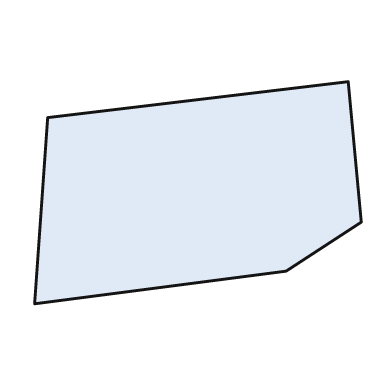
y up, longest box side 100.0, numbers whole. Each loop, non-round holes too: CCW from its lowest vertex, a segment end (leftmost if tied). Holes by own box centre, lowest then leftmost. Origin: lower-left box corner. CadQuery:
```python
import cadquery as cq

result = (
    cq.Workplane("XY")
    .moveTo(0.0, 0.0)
    .lineTo(77.0, 10.0)
    .lineTo(100.0, 25.0)
    .lineTo(96.0, 68.0)
    .lineTo(4.0, 57.0)
    .close()
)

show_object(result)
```